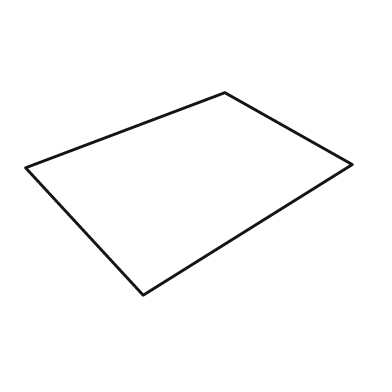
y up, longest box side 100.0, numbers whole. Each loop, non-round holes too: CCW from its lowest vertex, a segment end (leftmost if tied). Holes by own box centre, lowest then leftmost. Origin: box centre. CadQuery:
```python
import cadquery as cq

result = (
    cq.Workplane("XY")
    .moveTo(-14.0, -31.0)
    .lineTo(50.0, 9.0)
    .lineTo(11.0, 31.0)
    .lineTo(-50.0, 8.0)
    .close()
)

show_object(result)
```